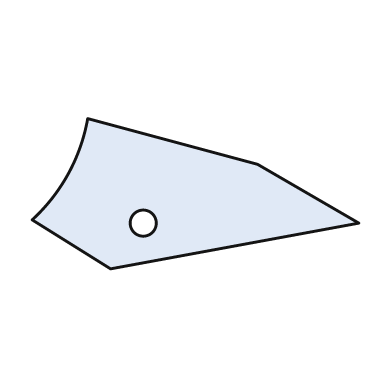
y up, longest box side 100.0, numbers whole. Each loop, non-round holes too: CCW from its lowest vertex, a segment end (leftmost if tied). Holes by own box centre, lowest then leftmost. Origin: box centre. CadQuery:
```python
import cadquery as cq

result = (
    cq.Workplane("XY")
    .moveTo(-26.0, -23.0)
    .lineTo(50.0, -9.0)
    .lineTo(19.0, 9.0)
    .lineTo(-33.0, 23.0)
    .threePointArc((-39.0, 6.0), (-50.0, -8.0))
    .close()
    .moveTo(-16.0, -9.0)
    .circle(4.0)
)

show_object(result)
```